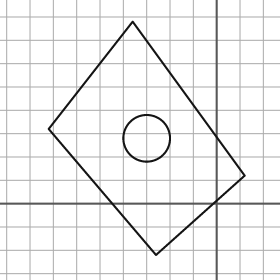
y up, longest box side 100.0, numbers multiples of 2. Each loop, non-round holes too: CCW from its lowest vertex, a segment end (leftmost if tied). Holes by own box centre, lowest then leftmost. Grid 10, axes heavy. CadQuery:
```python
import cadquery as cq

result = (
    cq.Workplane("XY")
    .moveTo(-26.0, -22.0)
    .lineTo(12.0, 12.0)
    .lineTo(-36.0, 78.0)
    .lineTo(-72.0, 32.0)
    .close()
    .moveTo(-30.0, 28.0)
    .circle(10.0)
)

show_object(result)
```